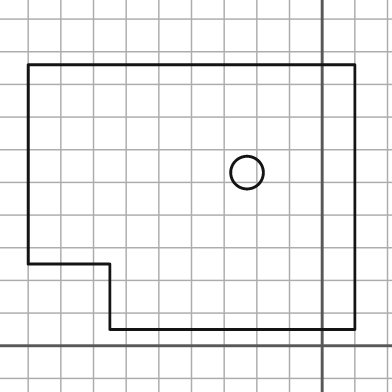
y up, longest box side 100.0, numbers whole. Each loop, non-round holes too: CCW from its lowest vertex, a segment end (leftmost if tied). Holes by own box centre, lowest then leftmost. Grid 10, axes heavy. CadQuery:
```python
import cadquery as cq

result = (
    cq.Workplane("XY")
    .moveTo(-65.0, 5.0)
    .lineTo(10.0, 5.0)
    .lineTo(10.0, 86.0)
    .lineTo(-90.0, 86.0)
    .lineTo(-90.0, 25.0)
    .lineTo(-65.0, 25.0)
    .close()
    .moveTo(-23.0, 53.0)
    .circle(5.0)
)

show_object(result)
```